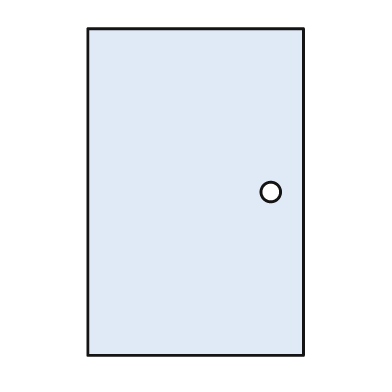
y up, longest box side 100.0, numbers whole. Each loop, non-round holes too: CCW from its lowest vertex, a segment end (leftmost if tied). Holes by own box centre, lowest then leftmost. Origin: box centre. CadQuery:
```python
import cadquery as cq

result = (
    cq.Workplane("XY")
    .moveTo(-33.0, -50.0)
    .lineTo(33.0, -50.0)
    .lineTo(33.0, 50.0)
    .lineTo(-33.0, 50.0)
    .close()
    .moveTo(23.0, 0.0)
    .circle(3.0)
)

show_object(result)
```